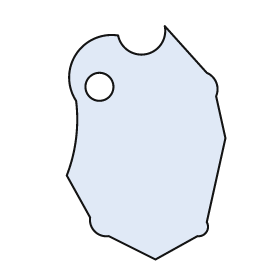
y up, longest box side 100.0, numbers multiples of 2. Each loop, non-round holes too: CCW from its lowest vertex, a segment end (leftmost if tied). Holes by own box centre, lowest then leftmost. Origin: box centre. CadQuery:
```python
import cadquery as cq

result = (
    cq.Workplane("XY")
    .moveTo(4.0, -50.0)
    .lineTo(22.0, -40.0)
    .threePointArc((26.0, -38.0), (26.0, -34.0))
    .lineTo(34.0, 2.0)
    .lineTo(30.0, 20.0)
    .threePointArc((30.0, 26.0), (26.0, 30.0))
    .lineTo(8.0, 50.0)
    .threePointArc((0.0, 38.0), (-12.0, 46.0))
    .threePointArc((-30.0, 38.0), (-30.0, 18.0))
    .threePointArc((-30.0, 2.0), (-34.0, -14.0))
    .lineTo(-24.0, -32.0)
    .threePointArc((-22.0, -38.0), (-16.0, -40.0))
    .close()
    .moveTo(-20.0, 24.0)
    .circle(6.0)
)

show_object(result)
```